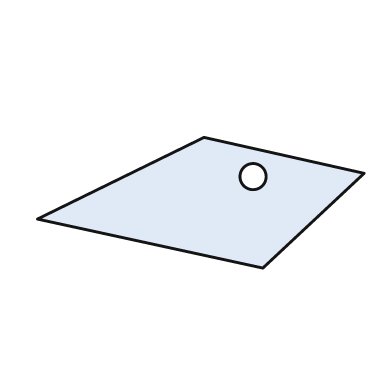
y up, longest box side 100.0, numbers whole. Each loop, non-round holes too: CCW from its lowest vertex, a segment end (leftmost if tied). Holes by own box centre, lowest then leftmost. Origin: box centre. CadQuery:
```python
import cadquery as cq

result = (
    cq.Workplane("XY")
    .moveTo(19.0, -20.0)
    .lineTo(50.0, 9.0)
    .lineTo(1.0, 20.0)
    .lineTo(-50.0, -5.0)
    .close()
    .moveTo(16.0, 8.0)
    .circle(4.0)
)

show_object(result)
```